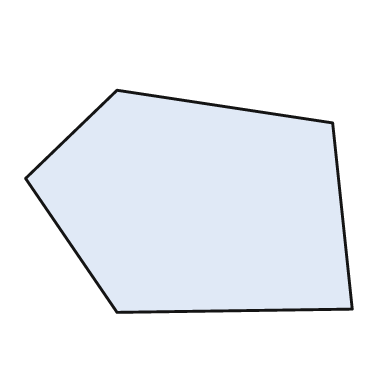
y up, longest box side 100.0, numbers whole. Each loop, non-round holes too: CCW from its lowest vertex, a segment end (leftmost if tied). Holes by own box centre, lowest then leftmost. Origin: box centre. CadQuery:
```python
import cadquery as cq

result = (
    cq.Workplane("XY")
    .moveTo(-22.0, -34.0)
    .lineTo(50.0, -33.0)
    .lineTo(44.0, 24.0)
    .lineTo(-22.0, 34.0)
    .lineTo(-50.0, 7.0)
    .close()
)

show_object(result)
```